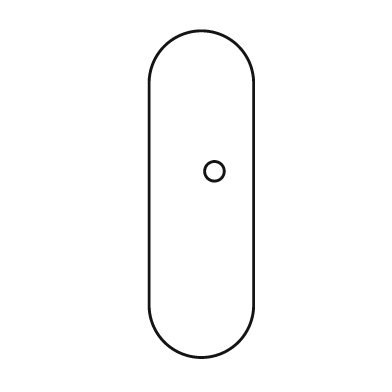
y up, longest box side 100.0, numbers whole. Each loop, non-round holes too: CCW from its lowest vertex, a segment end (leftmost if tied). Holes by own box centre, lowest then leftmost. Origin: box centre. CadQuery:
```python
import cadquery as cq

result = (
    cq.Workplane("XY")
    .moveTo(-16.0, -34.0)
    .threePointArc((0.0, -50.0), (16.0, -34.0))
    .lineTo(16.0, 34.0)
    .threePointArc((0.0, 50.0), (-16.0, 34.0))
    .close()
    .moveTo(4.0, 7.0)
    .circle(3.0)
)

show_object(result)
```